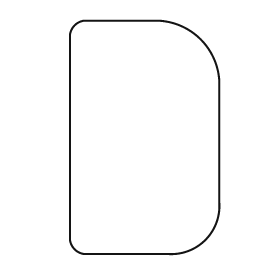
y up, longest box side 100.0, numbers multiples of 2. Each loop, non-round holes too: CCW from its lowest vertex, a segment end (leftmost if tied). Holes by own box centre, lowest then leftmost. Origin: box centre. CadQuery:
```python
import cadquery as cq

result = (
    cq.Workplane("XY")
    .moveTo(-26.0, -50.0)
    .lineTo(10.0, -50.0)
    .threePointArc((26.0, -44.0), (32.0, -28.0))
    .lineTo(32.0, 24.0)
    .threePointArc((24.0, 42.0), (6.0, 50.0))
    .lineTo(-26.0, 50.0)
    .threePointArc((-30.0, 48.0), (-32.0, 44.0))
    .lineTo(-32.0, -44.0)
    .threePointArc((-30.0, -48.0), (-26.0, -50.0))
    .close()
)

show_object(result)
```